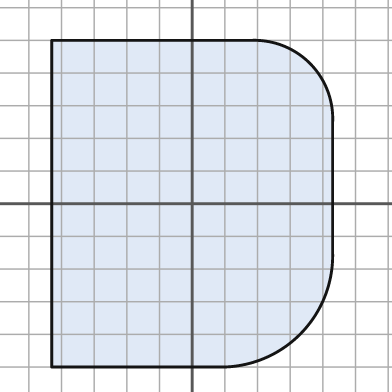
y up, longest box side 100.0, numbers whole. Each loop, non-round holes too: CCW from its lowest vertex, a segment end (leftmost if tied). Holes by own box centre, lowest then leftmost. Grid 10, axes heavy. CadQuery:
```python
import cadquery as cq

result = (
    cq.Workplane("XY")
    .moveTo(-43.0, -50.0)
    .lineTo(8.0, -50.0)
    .threePointArc((33.0, -40.0), (43.0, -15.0))
    .lineTo(43.0, 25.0)
    .threePointArc((36.0, 43.0), (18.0, 50.0))
    .lineTo(-43.0, 50.0)
    .close()
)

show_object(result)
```